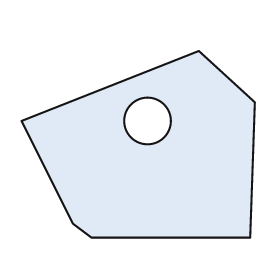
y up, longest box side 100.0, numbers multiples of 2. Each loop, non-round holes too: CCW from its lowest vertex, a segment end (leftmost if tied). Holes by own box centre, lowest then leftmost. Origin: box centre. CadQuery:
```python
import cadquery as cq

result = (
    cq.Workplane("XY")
    .moveTo(-20.0, -40.0)
    .lineTo(48.0, -40.0)
    .lineTo(50.0, 18.0)
    .lineTo(26.0, 40.0)
    .lineTo(-50.0, 10.0)
    .lineTo(-28.0, -34.0)
    .close()
    .moveTo(4.0, 10.0)
    .circle(10.0)
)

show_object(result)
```